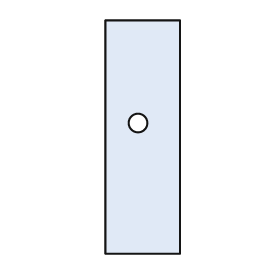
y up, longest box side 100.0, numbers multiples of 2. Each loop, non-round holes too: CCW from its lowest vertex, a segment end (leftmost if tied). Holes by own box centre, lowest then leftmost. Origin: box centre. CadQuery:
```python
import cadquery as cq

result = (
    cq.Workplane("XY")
    .moveTo(-16.0, -50.0)
    .lineTo(16.0, -50.0)
    .lineTo(16.0, 50.0)
    .lineTo(-16.0, 50.0)
    .close()
    .moveTo(-2.0, 6.0)
    .circle(4.0)
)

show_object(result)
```